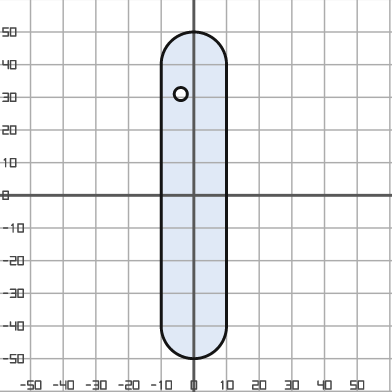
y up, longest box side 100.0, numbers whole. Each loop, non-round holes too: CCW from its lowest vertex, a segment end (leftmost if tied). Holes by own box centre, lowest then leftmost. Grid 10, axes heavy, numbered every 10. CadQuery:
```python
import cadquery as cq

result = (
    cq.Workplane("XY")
    .moveTo(-10.0, -40.0)
    .threePointArc((0.0, -50.0), (10.0, -40.0))
    .lineTo(10.0, 40.0)
    .threePointArc((0.0, 50.0), (-10.0, 40.0))
    .close()
    .moveTo(-4.0, 31.0)
    .circle(2.0)
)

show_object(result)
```